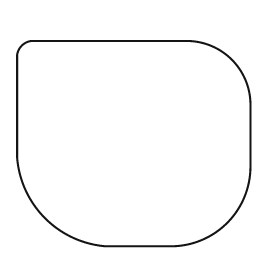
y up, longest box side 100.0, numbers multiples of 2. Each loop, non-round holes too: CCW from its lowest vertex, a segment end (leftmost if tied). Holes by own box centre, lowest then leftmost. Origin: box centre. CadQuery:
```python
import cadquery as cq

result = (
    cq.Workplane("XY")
    .moveTo(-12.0, -44.0)
    .lineTo(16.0, -44.0)
    .threePointArc((40.0, -34.0), (50.0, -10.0))
    .lineTo(50.0, 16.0)
    .threePointArc((42.0, 36.0), (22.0, 44.0))
    .lineTo(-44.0, 44.0)
    .threePointArc((-48.0, 42.0), (-50.0, 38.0))
    .lineTo(-50.0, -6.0)
    .threePointArc((-38.0, -32.0), (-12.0, -44.0))
    .close()
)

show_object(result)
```